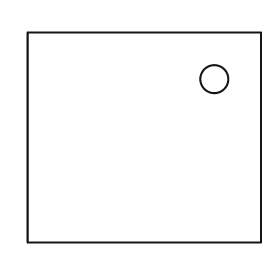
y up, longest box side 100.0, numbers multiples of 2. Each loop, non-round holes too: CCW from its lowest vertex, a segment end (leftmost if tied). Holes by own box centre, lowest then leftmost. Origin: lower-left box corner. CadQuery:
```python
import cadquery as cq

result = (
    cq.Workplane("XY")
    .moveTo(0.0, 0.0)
    .lineTo(100.0, 0.0)
    .lineTo(100.0, 90.0)
    .lineTo(0.0, 90.0)
    .close()
    .moveTo(80.0, 70.0)
    .circle(6.0)
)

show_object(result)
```